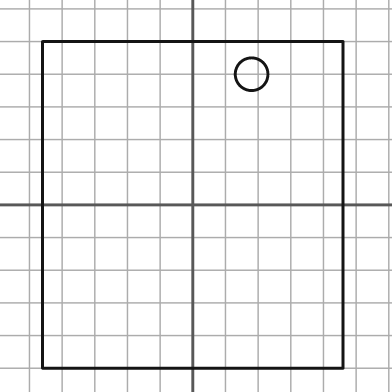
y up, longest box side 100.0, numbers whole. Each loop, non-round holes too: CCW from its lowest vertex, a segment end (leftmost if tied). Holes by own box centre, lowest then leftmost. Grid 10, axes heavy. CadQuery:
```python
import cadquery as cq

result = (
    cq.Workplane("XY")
    .moveTo(-46.0, -50.0)
    .lineTo(46.0, -50.0)
    .lineTo(46.0, 50.0)
    .lineTo(-46.0, 50.0)
    .close()
    .moveTo(18.0, 40.0)
    .circle(5.0)
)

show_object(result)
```